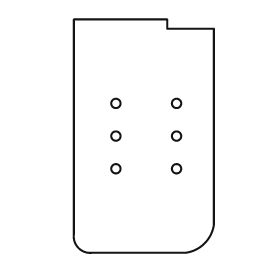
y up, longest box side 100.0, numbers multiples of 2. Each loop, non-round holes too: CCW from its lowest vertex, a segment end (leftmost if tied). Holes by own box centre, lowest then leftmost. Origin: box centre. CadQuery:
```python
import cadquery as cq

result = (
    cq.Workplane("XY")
    .moveTo(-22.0, -50.0)
    .lineTo(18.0, -50.0)
    .threePointArc((26.0, -46.0), (30.0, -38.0))
    .lineTo(30.0, 46.0)
    .lineTo(10.0, 46.0)
    .lineTo(10.0, 50.0)
    .lineTo(-30.0, 50.0)
    .lineTo(-30.0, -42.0)
    .threePointArc((-28.0, -48.0), (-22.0, -50.0))
    .close()
    .moveTo(-12.0, -14.0)
    .circle(2.0)
    .moveTo(14.0, -14.0)
    .circle(2.0)
    .moveTo(-12.0, 0.0)
    .circle(2.0)
    .moveTo(14.0, 0.0)
    .circle(2.0)
    .moveTo(-12.0, 14.0)
    .circle(2.0)
    .moveTo(14.0, 14.0)
    .circle(2.0)
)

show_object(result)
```